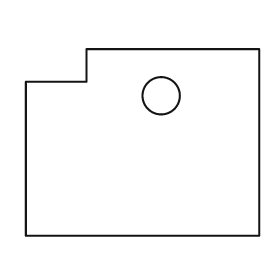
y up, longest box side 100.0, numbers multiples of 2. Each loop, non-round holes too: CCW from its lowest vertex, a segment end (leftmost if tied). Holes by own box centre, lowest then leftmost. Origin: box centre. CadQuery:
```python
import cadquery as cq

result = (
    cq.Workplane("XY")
    .moveTo(-50.0, -40.0)
    .lineTo(50.0, -40.0)
    .lineTo(50.0, 40.0)
    .lineTo(-24.0, 40.0)
    .lineTo(-24.0, 26.0)
    .lineTo(-50.0, 26.0)
    .close()
    .moveTo(8.0, 20.0)
    .circle(8.0)
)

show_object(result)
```